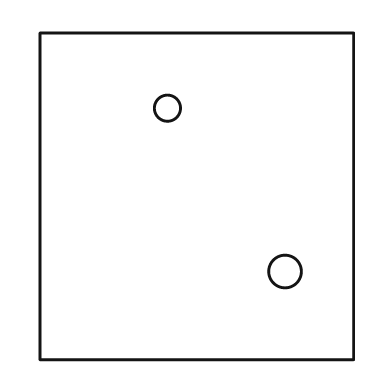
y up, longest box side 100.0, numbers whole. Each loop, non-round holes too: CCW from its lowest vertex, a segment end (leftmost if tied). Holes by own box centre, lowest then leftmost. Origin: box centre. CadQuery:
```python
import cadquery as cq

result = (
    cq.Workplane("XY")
    .moveTo(-48.0, -50.0)
    .lineTo(48.0, -50.0)
    .lineTo(48.0, 50.0)
    .lineTo(-48.0, 50.0)
    .close()
    .moveTo(27.0, -23.0)
    .circle(5.0)
    .moveTo(-9.0, 27.0)
    .circle(4.0)
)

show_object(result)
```